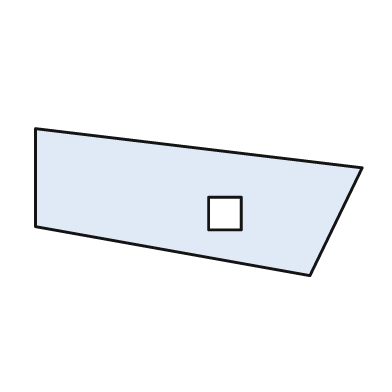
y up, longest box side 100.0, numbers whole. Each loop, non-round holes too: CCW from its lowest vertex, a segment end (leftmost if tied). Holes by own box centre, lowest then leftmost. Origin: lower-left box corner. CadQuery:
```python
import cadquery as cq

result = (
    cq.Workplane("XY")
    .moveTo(84.0, 0.0)
    .lineTo(100.0, 33.0)
    .lineTo(0.0, 45.0)
    .lineTo(0.0, 15.0)
    .close()
    .moveTo(53.0, 14.0)
    .lineTo(63.0, 14.0)
    .lineTo(63.0, 24.0)
    .lineTo(53.0, 24.0)
    .close()
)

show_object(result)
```